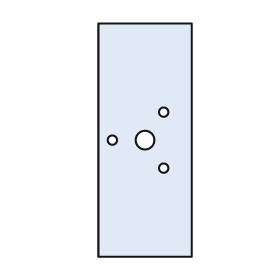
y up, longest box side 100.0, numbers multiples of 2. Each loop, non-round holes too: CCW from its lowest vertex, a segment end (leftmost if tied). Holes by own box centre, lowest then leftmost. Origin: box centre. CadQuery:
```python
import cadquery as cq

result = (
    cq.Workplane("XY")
    .moveTo(-20.0, -50.0)
    .lineTo(20.0, -50.0)
    .lineTo(20.0, 50.0)
    .lineTo(-20.0, 50.0)
    .close()
    .moveTo(8.0, -12.0)
    .circle(2.0)
    .moveTo(-14.0, 0.0)
    .circle(2.0)
    .moveTo(0.0, 0.0)
    .circle(4.0)
    .moveTo(8.0, 12.0)
    .circle(2.0)
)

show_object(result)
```